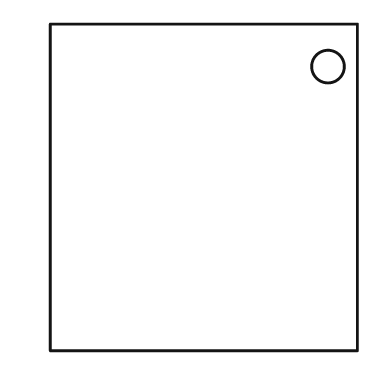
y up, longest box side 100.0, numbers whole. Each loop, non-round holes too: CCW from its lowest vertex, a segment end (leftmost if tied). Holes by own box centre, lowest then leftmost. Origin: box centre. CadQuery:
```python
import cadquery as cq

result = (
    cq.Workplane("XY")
    .moveTo(-47.0, -50.0)
    .lineTo(47.0, -50.0)
    .lineTo(47.0, 50.0)
    .lineTo(-47.0, 50.0)
    .close()
    .moveTo(38.0, 37.0)
    .circle(5.0)
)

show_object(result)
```